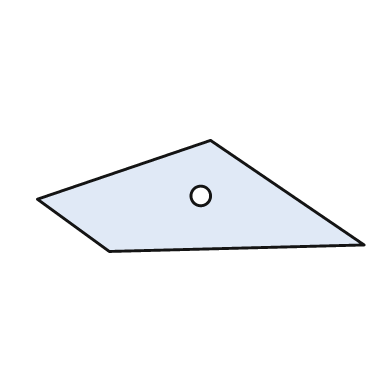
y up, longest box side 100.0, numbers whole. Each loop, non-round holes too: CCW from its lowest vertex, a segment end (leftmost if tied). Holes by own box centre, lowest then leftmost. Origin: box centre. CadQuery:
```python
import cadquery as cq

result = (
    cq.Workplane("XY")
    .moveTo(-28.0, -17.0)
    .lineTo(50.0, -15.0)
    .lineTo(3.0, 17.0)
    .lineTo(-50.0, -1.0)
    .close()
    .moveTo(0.0, 0.0)
    .circle(3.0)
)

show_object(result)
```